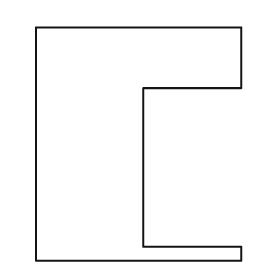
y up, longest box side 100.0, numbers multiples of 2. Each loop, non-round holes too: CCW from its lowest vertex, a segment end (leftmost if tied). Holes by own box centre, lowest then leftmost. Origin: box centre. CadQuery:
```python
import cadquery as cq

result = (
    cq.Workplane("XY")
    .moveTo(-44.0, -50.0)
    .lineTo(44.0, -50.0)
    .lineTo(44.0, -44.0)
    .lineTo(2.0, -44.0)
    .lineTo(2.0, 24.0)
    .lineTo(44.0, 24.0)
    .lineTo(44.0, 50.0)
    .lineTo(-44.0, 50.0)
    .close()
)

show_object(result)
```